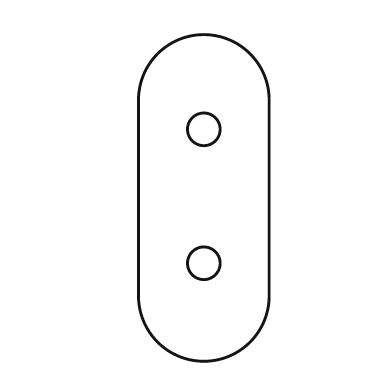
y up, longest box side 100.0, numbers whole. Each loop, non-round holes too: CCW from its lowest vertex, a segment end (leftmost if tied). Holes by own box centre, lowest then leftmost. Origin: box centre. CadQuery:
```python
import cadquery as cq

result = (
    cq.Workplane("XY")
    .moveTo(-20.0, -30.0)
    .threePointArc((0.0, -50.0), (20.0, -30.0))
    .lineTo(20.0, 30.0)
    .threePointArc((0.0, 50.0), (-20.0, 30.0))
    .close()
    .moveTo(0.0, -20.0)
    .circle(5.0)
    .moveTo(0.0, 21.0)
    .circle(5.0)
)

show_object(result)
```